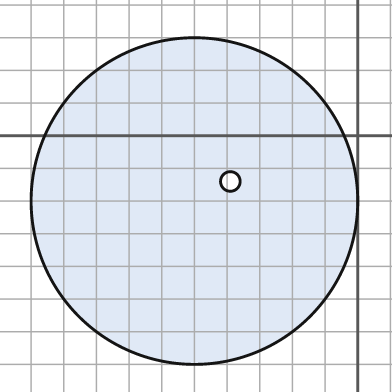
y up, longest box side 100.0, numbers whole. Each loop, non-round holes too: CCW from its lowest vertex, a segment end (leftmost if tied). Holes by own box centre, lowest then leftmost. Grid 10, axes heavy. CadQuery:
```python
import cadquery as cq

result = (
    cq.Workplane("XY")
    .moveTo(-50.0, -20.0)
    .circle(50.0)
    .moveTo(-39.0, -14.0)
    .circle(3.0)
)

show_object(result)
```